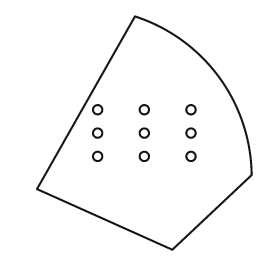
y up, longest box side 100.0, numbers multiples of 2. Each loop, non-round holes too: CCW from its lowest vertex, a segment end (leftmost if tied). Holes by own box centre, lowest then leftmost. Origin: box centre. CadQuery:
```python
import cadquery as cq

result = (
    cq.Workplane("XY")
    .moveTo(12.0, -50.0)
    .lineTo(46.0, -18.0)
    .threePointArc((32.0, 24.0), (-4.0, 50.0))
    .lineTo(-46.0, -24.0)
    .close()
    .moveTo(-20.0, -10.0)
    .circle(2.0)
    .moveTo(0.0, -10.0)
    .circle(2.0)
    .moveTo(20.0, -10.0)
    .circle(2.0)
    .moveTo(-20.0, 0.0)
    .circle(2.0)
    .moveTo(0.0, 0.0)
    .circle(2.0)
    .moveTo(20.0, 0.0)
    .circle(2.0)
    .moveTo(-20.0, 10.0)
    .circle(2.0)
    .moveTo(0.0, 10.0)
    .circle(2.0)
    .moveTo(20.0, 10.0)
    .circle(2.0)
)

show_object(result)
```